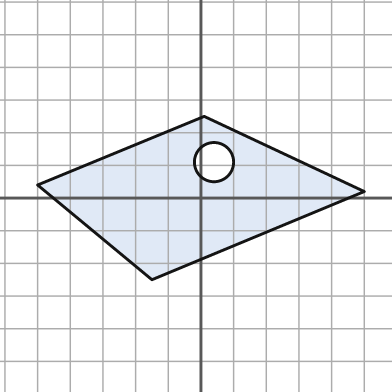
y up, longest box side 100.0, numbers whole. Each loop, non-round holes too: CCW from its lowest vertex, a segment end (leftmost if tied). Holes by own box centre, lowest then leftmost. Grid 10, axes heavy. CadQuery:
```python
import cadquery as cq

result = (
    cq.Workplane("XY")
    .moveTo(-15.0, -25.0)
    .lineTo(50.0, 2.0)
    .lineTo(1.0, 25.0)
    .lineTo(-50.0, 4.0)
    .close()
    .moveTo(4.0, 11.0)
    .circle(6.0)
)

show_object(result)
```